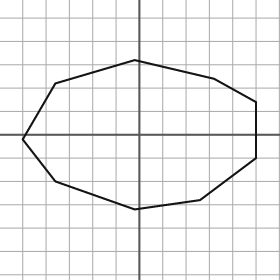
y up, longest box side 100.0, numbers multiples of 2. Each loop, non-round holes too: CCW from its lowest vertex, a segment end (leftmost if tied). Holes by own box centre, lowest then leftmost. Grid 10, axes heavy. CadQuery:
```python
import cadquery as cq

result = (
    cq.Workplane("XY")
    .moveTo(-2.0, -32.0)
    .lineTo(26.0, -28.0)
    .lineTo(50.0, -10.0)
    .lineTo(50.0, 14.0)
    .lineTo(32.0, 24.0)
    .lineTo(-2.0, 32.0)
    .lineTo(-36.0, 22.0)
    .lineTo(-50.0, -2.0)
    .lineTo(-36.0, -20.0)
    .close()
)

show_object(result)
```